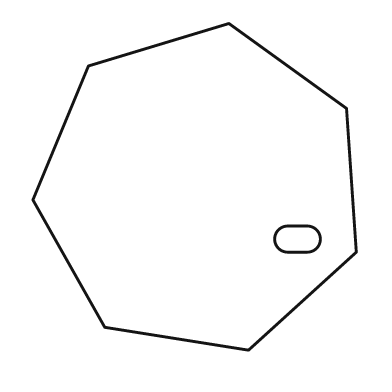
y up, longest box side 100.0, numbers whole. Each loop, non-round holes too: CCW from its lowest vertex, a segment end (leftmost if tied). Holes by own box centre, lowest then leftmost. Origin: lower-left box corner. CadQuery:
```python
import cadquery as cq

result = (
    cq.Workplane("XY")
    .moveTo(66.0, 0.0)
    .lineTo(99.0, 30.0)
    .lineTo(96.0, 74.0)
    .lineTo(60.0, 100.0)
    .lineTo(17.0, 87.0)
    .lineTo(0.0, 46.0)
    .lineTo(22.0, 7.0)
    .close()
    .moveTo(78.0, 30.0)
    .lineTo(84.0, 30.0)
    .threePointArc((88.0, 34.0), (84.0, 38.0))
    .lineTo(78.0, 38.0)
    .threePointArc((74.0, 34.0), (78.0, 30.0))
    .close()
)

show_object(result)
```